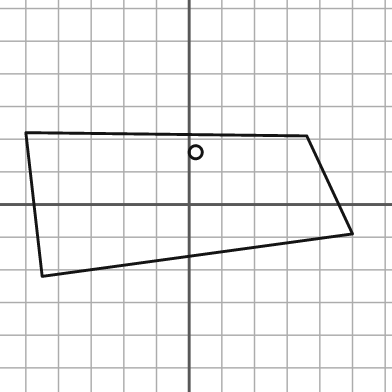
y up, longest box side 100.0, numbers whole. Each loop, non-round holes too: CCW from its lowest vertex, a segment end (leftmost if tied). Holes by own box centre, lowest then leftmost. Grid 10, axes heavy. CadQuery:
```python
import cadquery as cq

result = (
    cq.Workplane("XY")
    .moveTo(-45.0, -22.0)
    .lineTo(50.0, -9.0)
    .lineTo(36.0, 21.0)
    .lineTo(-50.0, 22.0)
    .close()
    .moveTo(2.0, 16.0)
    .circle(2.0)
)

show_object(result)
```